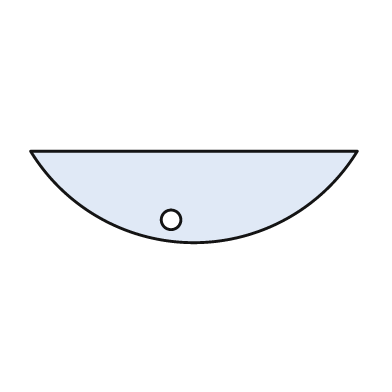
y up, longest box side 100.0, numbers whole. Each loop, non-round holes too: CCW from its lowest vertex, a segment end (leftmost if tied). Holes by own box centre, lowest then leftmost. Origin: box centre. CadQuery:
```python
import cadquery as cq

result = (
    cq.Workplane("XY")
    .moveTo(-50.0, 14.0)
    .threePointArc((0.0, -14.0), (50.0, 14.0))
    .close()
    .moveTo(-7.0, -7.0)
    .circle(3.0)
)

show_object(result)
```